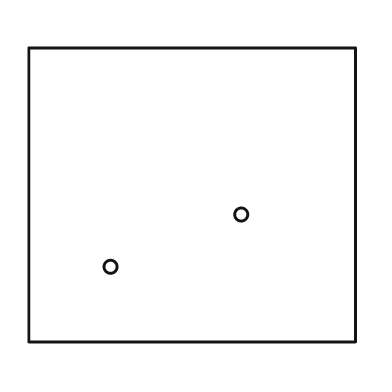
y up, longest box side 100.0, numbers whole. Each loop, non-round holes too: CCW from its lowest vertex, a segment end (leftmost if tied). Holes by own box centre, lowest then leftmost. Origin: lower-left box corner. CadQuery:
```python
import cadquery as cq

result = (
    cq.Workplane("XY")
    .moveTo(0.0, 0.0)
    .lineTo(100.0, 0.0)
    .lineTo(100.0, 90.0)
    .lineTo(0.0, 90.0)
    .close()
    .moveTo(25.0, 23.0)
    .circle(2.0)
    .moveTo(65.0, 39.0)
    .circle(2.0)
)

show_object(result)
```